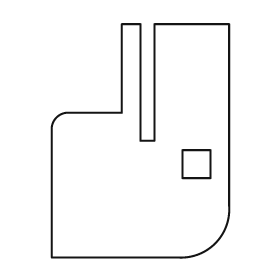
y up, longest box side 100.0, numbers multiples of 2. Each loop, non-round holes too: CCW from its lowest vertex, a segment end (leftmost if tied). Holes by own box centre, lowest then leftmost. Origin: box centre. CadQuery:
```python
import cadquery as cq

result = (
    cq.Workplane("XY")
    .moveTo(-38.0, -50.0)
    .lineTo(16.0, -50.0)
    .threePointArc((32.0, -44.0), (38.0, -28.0))
    .lineTo(38.0, 50.0)
    .lineTo(6.0, 50.0)
    .lineTo(6.0, 0.0)
    .lineTo(0.0, 0.0)
    .lineTo(0.0, 50.0)
    .lineTo(-8.0, 50.0)
    .lineTo(-8.0, 12.0)
    .lineTo(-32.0, 12.0)
    .threePointArc((-36.0, 10.0), (-38.0, 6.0))
    .close()
    .moveTo(18.0, -16.0)
    .lineTo(30.0, -16.0)
    .lineTo(30.0, -4.0)
    .lineTo(18.0, -4.0)
    .close()
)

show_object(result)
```